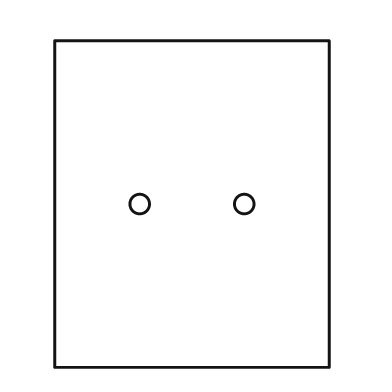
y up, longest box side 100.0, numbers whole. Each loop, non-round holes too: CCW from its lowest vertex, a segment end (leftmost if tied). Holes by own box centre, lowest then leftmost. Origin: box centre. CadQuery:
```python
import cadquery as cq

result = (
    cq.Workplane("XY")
    .moveTo(-42.0, -50.0)
    .lineTo(42.0, -50.0)
    .lineTo(42.0, 50.0)
    .lineTo(-42.0, 50.0)
    .close()
    .moveTo(-16.0, 0.0)
    .circle(3.0)
    .moveTo(16.0, 0.0)
    .circle(3.0)
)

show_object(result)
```